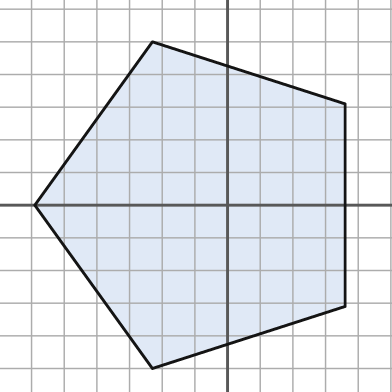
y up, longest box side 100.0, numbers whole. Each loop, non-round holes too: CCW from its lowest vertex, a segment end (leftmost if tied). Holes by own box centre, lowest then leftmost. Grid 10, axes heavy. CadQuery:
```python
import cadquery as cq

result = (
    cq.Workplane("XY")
    .moveTo(-23.0, -50.0)
    .lineTo(36.0, -31.0)
    .lineTo(36.0, 31.0)
    .lineTo(-23.0, 50.0)
    .lineTo(-59.0, 0.0)
    .close()
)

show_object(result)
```